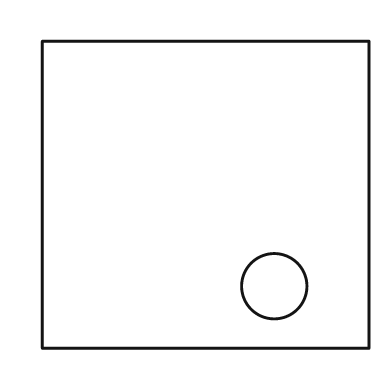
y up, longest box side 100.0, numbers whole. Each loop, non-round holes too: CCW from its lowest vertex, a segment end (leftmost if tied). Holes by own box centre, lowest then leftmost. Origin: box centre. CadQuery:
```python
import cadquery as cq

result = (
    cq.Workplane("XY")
    .moveTo(-50.0, -47.0)
    .lineTo(50.0, -47.0)
    .lineTo(50.0, 47.0)
    .lineTo(-50.0, 47.0)
    .close()
    .moveTo(21.0, -28.0)
    .circle(10.0)
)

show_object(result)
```